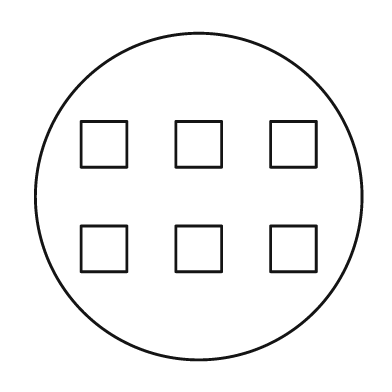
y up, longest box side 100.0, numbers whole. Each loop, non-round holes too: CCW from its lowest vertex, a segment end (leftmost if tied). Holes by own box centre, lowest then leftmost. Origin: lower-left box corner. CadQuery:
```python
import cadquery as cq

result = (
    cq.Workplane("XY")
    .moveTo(50.0, 50.0)
    .circle(50.0)
    .moveTo(14.0, 27.0)
    .lineTo(28.0, 27.0)
    .lineTo(28.0, 41.0)
    .lineTo(14.0, 41.0)
    .close()
    .moveTo(43.0, 27.0)
    .lineTo(57.0, 27.0)
    .lineTo(57.0, 41.0)
    .lineTo(43.0, 41.0)
    .close()
    .moveTo(72.0, 27.0)
    .lineTo(86.0, 27.0)
    .lineTo(86.0, 41.0)
    .lineTo(72.0, 41.0)
    .close()
    .moveTo(14.0, 59.0)
    .lineTo(28.0, 59.0)
    .lineTo(28.0, 73.0)
    .lineTo(14.0, 73.0)
    .close()
    .moveTo(43.0, 59.0)
    .lineTo(57.0, 59.0)
    .lineTo(57.0, 73.0)
    .lineTo(43.0, 73.0)
    .close()
    .moveTo(72.0, 59.0)
    .lineTo(86.0, 59.0)
    .lineTo(86.0, 73.0)
    .lineTo(72.0, 73.0)
    .close()
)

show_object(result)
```